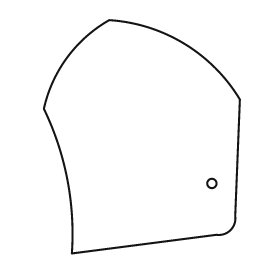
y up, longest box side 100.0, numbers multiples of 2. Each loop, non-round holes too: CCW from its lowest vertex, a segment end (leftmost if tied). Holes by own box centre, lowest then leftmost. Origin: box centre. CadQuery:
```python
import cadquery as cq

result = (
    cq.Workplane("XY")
    .moveTo(-30.0, -50.0)
    .lineTo(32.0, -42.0)
    .threePointArc((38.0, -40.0), (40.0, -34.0))
    .lineTo(42.0, 16.0)
    .threePointArc((18.0, 40.0), (-14.0, 50.0))
    .threePointArc((-32.0, 34.0), (-42.0, 12.0))
    .threePointArc((-32.0, -18.0), (-30.0, -50.0))
    .close()
    .moveTo(30.0, -20.0)
    .circle(2.0)
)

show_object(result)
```